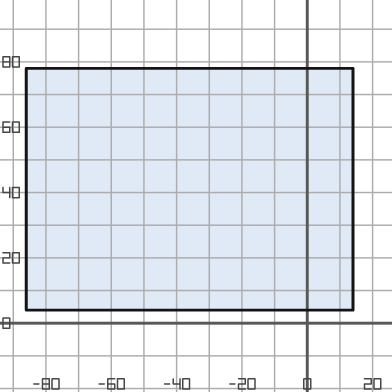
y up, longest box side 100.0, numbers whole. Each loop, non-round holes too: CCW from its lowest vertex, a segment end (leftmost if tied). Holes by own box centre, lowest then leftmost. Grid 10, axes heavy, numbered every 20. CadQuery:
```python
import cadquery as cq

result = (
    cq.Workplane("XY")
    .moveTo(-86.0, 4.0)
    .lineTo(14.0, 4.0)
    .lineTo(14.0, 78.0)
    .lineTo(-86.0, 78.0)
    .close()
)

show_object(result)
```